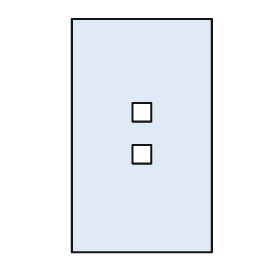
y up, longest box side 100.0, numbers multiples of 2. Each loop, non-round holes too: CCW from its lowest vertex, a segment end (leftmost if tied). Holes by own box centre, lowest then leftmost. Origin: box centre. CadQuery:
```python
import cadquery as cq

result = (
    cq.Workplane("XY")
    .moveTo(-30.0, -50.0)
    .lineTo(30.0, -50.0)
    .lineTo(30.0, 50.0)
    .lineTo(-30.0, 50.0)
    .close()
    .moveTo(-4.0, -12.0)
    .lineTo(4.0, -12.0)
    .lineTo(4.0, -4.0)
    .lineTo(-4.0, -4.0)
    .close()
    .moveTo(-4.0, 6.0)
    .lineTo(4.0, 6.0)
    .lineTo(4.0, 14.0)
    .lineTo(-4.0, 14.0)
    .close()
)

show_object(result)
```